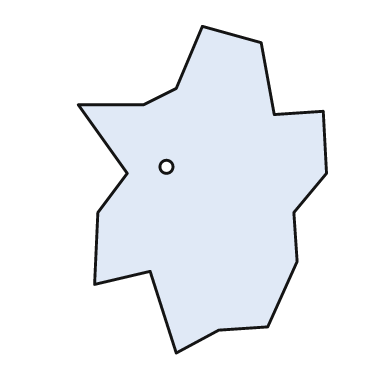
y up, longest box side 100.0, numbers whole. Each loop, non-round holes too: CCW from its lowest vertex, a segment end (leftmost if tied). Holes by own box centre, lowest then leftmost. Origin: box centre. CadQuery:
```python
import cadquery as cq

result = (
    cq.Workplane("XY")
    .moveTo(-8.0, -50.0)
    .lineTo(5.0, -43.0)
    .lineTo(20.0, -42.0)
    .lineTo(29.0, -22.0)
    .lineTo(28.0, -7.0)
    .lineTo(38.0, 5.0)
    .lineTo(37.0, 24.0)
    .lineTo(22.0, 23.0)
    .lineTo(18.0, 45.0)
    .lineTo(0.0, 50.0)
    .lineTo(-8.0, 31.0)
    .lineTo(-18.0, 26.0)
    .lineTo(-38.0, 26.0)
    .lineTo(-23.0, 5.0)
    .lineTo(-32.0, -7.0)
    .lineTo(-33.0, -29.0)
    .lineTo(-16.0, -25.0)
    .close()
    .moveTo(-11.0, 7.0)
    .circle(2.0)
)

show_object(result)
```